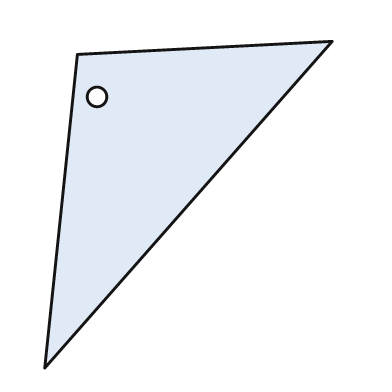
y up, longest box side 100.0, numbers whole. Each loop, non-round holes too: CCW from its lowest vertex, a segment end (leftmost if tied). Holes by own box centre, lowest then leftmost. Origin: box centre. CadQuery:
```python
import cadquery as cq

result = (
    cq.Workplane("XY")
    .moveTo(-44.0, -50.0)
    .lineTo(44.0, 50.0)
    .lineTo(-34.0, 46.0)
    .close()
    .moveTo(-28.0, 33.0)
    .circle(3.0)
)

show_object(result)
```